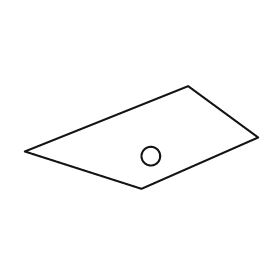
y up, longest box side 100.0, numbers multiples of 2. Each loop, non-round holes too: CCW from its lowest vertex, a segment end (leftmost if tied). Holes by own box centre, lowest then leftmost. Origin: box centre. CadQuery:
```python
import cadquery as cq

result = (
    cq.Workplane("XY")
    .moveTo(0.0, -22.0)
    .lineTo(50.0, 0.0)
    .lineTo(20.0, 22.0)
    .lineTo(-50.0, -6.0)
    .close()
    .moveTo(4.0, -8.0)
    .circle(4.0)
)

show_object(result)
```